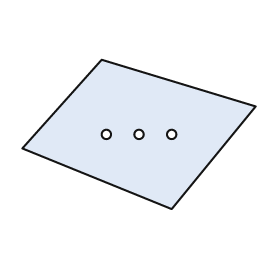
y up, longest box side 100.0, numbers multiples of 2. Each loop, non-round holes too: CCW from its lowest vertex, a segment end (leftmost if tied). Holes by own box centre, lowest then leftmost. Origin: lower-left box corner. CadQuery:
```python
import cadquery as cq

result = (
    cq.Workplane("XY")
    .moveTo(64.0, 0.0)
    .lineTo(100.0, 44.0)
    .lineTo(34.0, 64.0)
    .lineTo(0.0, 26.0)
    .close()
    .moveTo(36.0, 32.0)
    .circle(2.0)
    .moveTo(50.0, 32.0)
    .circle(2.0)
    .moveTo(64.0, 32.0)
    .circle(2.0)
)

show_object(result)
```